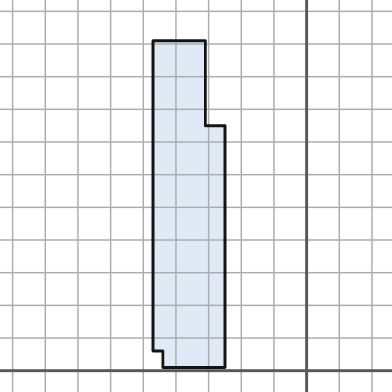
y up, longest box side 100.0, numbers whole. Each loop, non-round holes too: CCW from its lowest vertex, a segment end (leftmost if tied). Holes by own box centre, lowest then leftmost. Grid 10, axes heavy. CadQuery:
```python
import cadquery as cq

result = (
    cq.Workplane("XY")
    .moveTo(-44.0, 1.0)
    .lineTo(-25.0, 1.0)
    .lineTo(-25.0, 75.0)
    .lineTo(-31.0, 75.0)
    .lineTo(-31.0, 101.0)
    .lineTo(-47.0, 101.0)
    .lineTo(-47.0, 6.0)
    .lineTo(-44.0, 6.0)
    .close()
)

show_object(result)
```